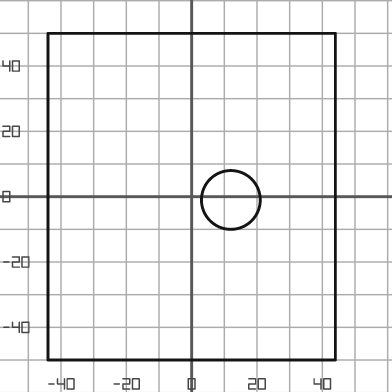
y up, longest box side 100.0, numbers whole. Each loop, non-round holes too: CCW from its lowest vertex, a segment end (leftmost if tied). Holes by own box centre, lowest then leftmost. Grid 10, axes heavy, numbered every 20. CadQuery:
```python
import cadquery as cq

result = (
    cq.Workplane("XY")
    .moveTo(-44.0, -50.0)
    .lineTo(44.0, -50.0)
    .lineTo(44.0, 50.0)
    .lineTo(-44.0, 50.0)
    .close()
    .moveTo(12.0, -1.0)
    .circle(9.0)
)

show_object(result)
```